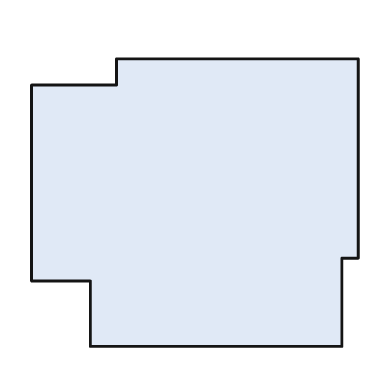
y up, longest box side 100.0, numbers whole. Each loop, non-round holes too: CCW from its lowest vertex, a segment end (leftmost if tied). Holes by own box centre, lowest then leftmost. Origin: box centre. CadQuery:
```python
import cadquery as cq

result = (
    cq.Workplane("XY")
    .moveTo(-32.0, -44.0)
    .lineTo(45.0, -44.0)
    .lineTo(45.0, -17.0)
    .lineTo(50.0, -17.0)
    .lineTo(50.0, 44.0)
    .lineTo(-24.0, 44.0)
    .lineTo(-24.0, 36.0)
    .lineTo(-50.0, 36.0)
    .lineTo(-50.0, -24.0)
    .lineTo(-32.0, -24.0)
    .close()
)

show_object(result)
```